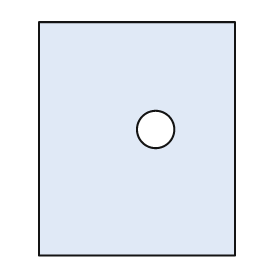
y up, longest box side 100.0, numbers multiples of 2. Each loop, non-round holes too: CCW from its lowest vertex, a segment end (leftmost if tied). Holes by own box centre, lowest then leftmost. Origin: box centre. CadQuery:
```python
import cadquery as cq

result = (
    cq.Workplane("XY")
    .moveTo(-42.0, -50.0)
    .lineTo(42.0, -50.0)
    .lineTo(42.0, 50.0)
    .lineTo(-42.0, 50.0)
    .close()
    .moveTo(8.0, 4.0)
    .circle(8.0)
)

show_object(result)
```